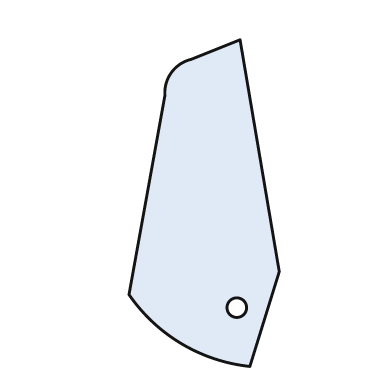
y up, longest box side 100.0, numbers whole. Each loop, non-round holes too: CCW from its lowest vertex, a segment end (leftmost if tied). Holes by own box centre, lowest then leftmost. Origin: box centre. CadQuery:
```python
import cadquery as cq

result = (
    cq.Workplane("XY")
    .moveTo(14.0, -50.0)
    .lineTo(23.0, -21.0)
    .lineTo(11.0, 50.0)
    .lineTo(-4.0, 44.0)
    .threePointArc((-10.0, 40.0), (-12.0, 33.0))
    .lineTo(-23.0, -28.0)
    .threePointArc((-7.0, -43.0), (14.0, -50.0))
    .close()
    .moveTo(10.0, -32.0)
    .circle(3.0)
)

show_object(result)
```